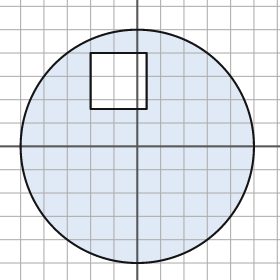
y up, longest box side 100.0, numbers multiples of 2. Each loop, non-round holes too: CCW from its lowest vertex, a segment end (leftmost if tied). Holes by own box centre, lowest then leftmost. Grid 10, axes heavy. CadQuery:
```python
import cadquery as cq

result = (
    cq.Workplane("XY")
    .moveTo(0.0, 0.0)
    .circle(50.0)
    .moveTo(-20.0, 16.0)
    .lineTo(4.0, 16.0)
    .lineTo(4.0, 40.0)
    .lineTo(-20.0, 40.0)
    .close()
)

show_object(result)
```